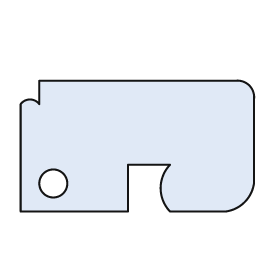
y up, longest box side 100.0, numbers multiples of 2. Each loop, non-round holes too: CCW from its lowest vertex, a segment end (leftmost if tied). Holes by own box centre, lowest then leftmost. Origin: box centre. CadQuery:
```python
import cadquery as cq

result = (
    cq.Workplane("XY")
    .moveTo(-50.0, -28.0)
    .lineTo(-4.0, -28.0)
    .lineTo(-4.0, -8.0)
    .lineTo(14.0, -8.0)
    .threePointArc((10.0, -18.0), (14.0, -28.0))
    .lineTo(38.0, -28.0)
    .threePointArc((46.0, -24.0), (50.0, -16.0))
    .lineTo(50.0, 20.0)
    .threePointArc((48.0, 26.0), (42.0, 28.0))
    .lineTo(-42.0, 28.0)
    .lineTo(-42.0, 18.0)
    .threePointArc((-46.0, 20.0), (-50.0, 18.0))
    .close()
    .moveTo(-36.0, -16.0)
    .circle(6.0)
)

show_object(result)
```